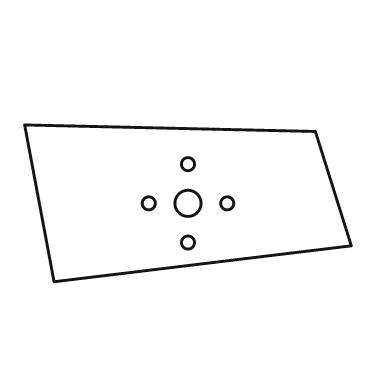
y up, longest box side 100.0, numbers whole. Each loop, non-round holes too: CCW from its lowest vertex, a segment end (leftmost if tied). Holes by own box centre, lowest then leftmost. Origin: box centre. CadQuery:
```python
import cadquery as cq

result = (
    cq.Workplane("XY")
    .moveTo(-41.0, -24.0)
    .lineTo(50.0, -13.0)
    .lineTo(39.0, 22.0)
    .lineTo(-50.0, 24.0)
    .close()
    .moveTo(0.0, -12.0)
    .circle(2.0)
    .moveTo(-12.0, 0.0)
    .circle(2.0)
    .moveTo(0.0, 0.0)
    .circle(4.0)
    .moveTo(12.0, 0.0)
    .circle(2.0)
    .moveTo(0.0, 12.0)
    .circle(2.0)
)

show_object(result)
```